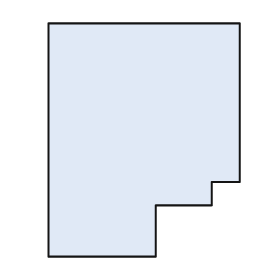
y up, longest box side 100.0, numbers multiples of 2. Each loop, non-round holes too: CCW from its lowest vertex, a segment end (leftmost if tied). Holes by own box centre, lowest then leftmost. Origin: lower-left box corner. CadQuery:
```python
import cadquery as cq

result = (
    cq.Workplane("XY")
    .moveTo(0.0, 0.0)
    .lineTo(46.0, 0.0)
    .lineTo(46.0, 22.0)
    .lineTo(70.0, 22.0)
    .lineTo(70.0, 32.0)
    .lineTo(82.0, 32.0)
    .lineTo(82.0, 100.0)
    .lineTo(0.0, 100.0)
    .close()
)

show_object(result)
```